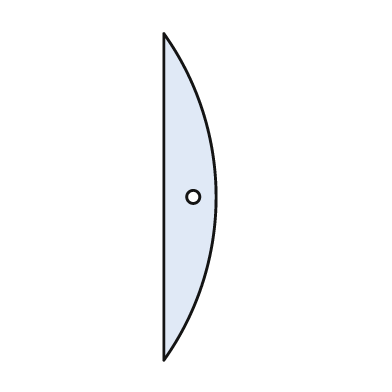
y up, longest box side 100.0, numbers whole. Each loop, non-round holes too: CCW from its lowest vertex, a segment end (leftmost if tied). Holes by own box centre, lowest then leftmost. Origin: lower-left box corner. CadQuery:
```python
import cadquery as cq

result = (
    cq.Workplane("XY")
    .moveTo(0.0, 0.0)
    .threePointArc((16.0, 50.0), (0.0, 100.0))
    .close()
    .moveTo(9.0, 50.0)
    .circle(2.0)
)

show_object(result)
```